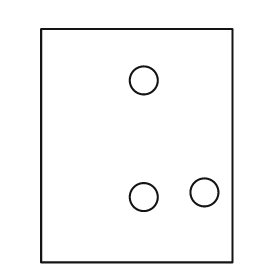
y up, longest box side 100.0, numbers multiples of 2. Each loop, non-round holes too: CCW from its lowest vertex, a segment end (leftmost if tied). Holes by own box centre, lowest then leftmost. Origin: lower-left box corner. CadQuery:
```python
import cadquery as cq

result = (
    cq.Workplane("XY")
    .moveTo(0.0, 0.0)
    .lineTo(82.0, 0.0)
    .lineTo(82.0, 100.0)
    .lineTo(0.0, 100.0)
    .close()
    .moveTo(44.0, 28.0)
    .circle(6.0)
    .moveTo(70.0, 30.0)
    .circle(6.0)
    .moveTo(44.0, 78.0)
    .circle(6.0)
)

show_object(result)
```